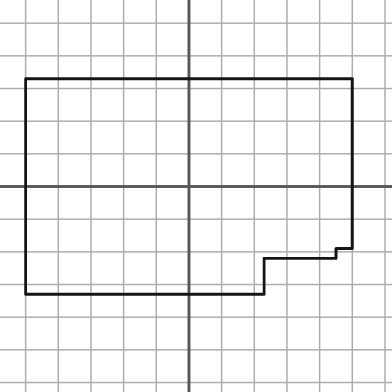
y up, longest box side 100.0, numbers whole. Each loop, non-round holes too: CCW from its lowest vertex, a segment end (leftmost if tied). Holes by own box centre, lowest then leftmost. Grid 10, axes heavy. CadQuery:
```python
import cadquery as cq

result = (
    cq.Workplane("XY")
    .moveTo(-50.0, -33.0)
    .lineTo(23.0, -33.0)
    .lineTo(23.0, -22.0)
    .lineTo(45.0, -22.0)
    .lineTo(45.0, -19.0)
    .lineTo(50.0, -19.0)
    .lineTo(50.0, 33.0)
    .lineTo(-50.0, 33.0)
    .close()
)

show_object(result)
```